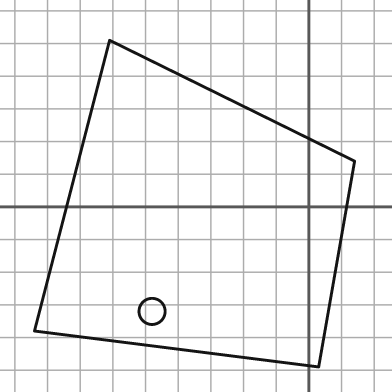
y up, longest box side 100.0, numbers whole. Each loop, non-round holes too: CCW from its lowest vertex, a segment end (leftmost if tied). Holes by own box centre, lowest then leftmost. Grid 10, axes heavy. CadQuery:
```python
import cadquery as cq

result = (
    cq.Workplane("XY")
    .moveTo(3.0, -49.0)
    .lineTo(14.0, 14.0)
    .lineTo(-61.0, 51.0)
    .lineTo(-84.0, -38.0)
    .close()
    .moveTo(-48.0, -32.0)
    .circle(4.0)
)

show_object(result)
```